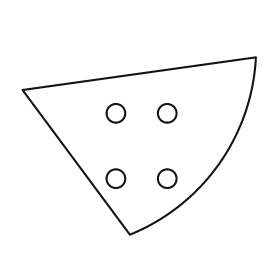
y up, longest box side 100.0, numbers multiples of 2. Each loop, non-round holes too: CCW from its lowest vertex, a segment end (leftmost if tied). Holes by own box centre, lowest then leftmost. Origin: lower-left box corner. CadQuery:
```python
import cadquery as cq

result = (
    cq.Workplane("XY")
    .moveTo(46.0, 0.0)
    .threePointArc((84.0, 30.0), (100.0, 76.0))
    .lineTo(0.0, 62.0)
    .close()
    .moveTo(40.0, 24.0)
    .circle(4.0)
    .moveTo(62.0, 24.0)
    .circle(4.0)
    .moveTo(40.0, 52.0)
    .circle(4.0)
    .moveTo(62.0, 52.0)
    .circle(4.0)
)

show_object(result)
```